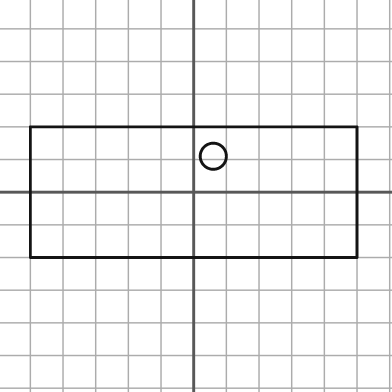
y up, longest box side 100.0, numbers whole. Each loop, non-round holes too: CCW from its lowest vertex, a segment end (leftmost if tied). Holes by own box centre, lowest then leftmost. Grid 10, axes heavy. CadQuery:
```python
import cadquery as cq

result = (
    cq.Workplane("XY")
    .moveTo(-50.0, -20.0)
    .lineTo(50.0, -20.0)
    .lineTo(50.0, 20.0)
    .lineTo(-50.0, 20.0)
    .close()
    .moveTo(6.0, 11.0)
    .circle(4.0)
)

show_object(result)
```